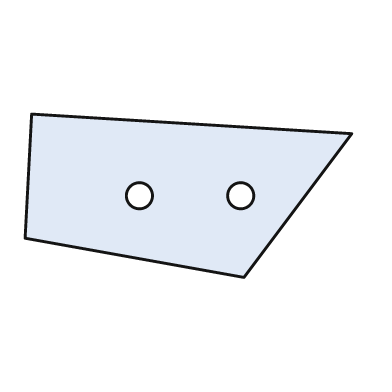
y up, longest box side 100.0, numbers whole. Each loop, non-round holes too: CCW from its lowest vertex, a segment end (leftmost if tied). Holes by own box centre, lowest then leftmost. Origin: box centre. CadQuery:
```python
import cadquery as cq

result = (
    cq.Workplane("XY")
    .moveTo(17.0, -25.0)
    .lineTo(50.0, 19.0)
    .lineTo(-48.0, 25.0)
    .lineTo(-50.0, -13.0)
    .close()
    .moveTo(-15.0, 0.0)
    .circle(4.0)
    .moveTo(16.0, 0.0)
    .circle(4.0)
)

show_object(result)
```